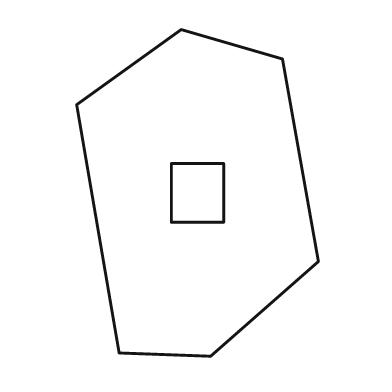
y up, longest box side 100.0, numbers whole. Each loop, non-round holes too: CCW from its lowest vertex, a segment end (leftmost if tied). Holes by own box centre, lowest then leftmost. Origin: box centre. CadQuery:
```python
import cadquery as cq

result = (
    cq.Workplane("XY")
    .moveTo(4.0, -50.0)
    .lineTo(37.0, -21.0)
    .lineTo(26.0, 41.0)
    .lineTo(-5.0, 50.0)
    .lineTo(-37.0, 27.0)
    .lineTo(-24.0, -49.0)
    .close()
    .moveTo(-8.0, -9.0)
    .lineTo(8.0, -9.0)
    .lineTo(8.0, 9.0)
    .lineTo(-8.0, 9.0)
    .close()
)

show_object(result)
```